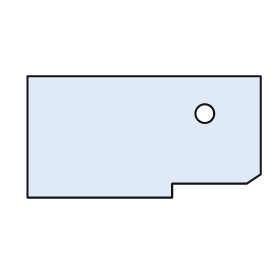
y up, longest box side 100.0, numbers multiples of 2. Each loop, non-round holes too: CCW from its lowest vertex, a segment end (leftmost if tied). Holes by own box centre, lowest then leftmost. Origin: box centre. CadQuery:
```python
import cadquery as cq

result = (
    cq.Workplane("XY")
    .moveTo(-50.0, -26.0)
    .lineTo(12.0, -26.0)
    .lineTo(12.0, -20.0)
    .lineTo(44.0, -20.0)
    .lineTo(50.0, -16.0)
    .lineTo(50.0, 26.0)
    .lineTo(-50.0, 26.0)
    .close()
    .moveTo(26.0, 10.0)
    .circle(4.0)
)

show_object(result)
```